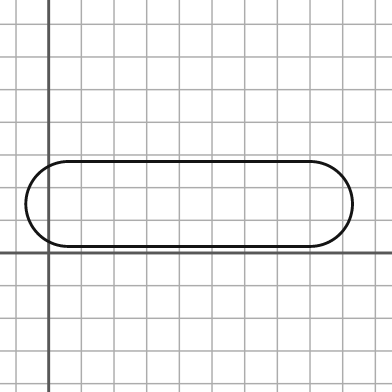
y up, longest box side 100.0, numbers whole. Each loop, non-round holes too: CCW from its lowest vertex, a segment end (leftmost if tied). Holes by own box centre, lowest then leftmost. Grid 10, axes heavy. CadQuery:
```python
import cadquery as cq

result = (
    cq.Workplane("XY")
    .moveTo(6.0, 2.0)
    .lineTo(80.0, 2.0)
    .threePointArc((93.0, 15.0), (80.0, 28.0))
    .lineTo(6.0, 28.0)
    .threePointArc((-7.0, 15.0), (6.0, 2.0))
    .close()
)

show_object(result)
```